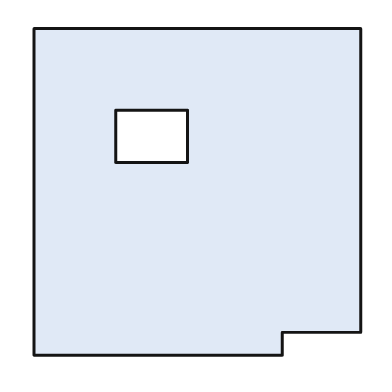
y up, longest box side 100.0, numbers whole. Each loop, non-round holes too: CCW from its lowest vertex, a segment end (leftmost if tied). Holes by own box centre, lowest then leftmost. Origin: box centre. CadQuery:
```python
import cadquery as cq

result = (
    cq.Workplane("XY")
    .moveTo(-50.0, -50.0)
    .lineTo(26.0, -50.0)
    .lineTo(26.0, -43.0)
    .lineTo(50.0, -43.0)
    .lineTo(50.0, 50.0)
    .lineTo(-50.0, 50.0)
    .close()
    .moveTo(-25.0, 9.0)
    .lineTo(-3.0, 9.0)
    .lineTo(-3.0, 25.0)
    .lineTo(-25.0, 25.0)
    .close()
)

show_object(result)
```